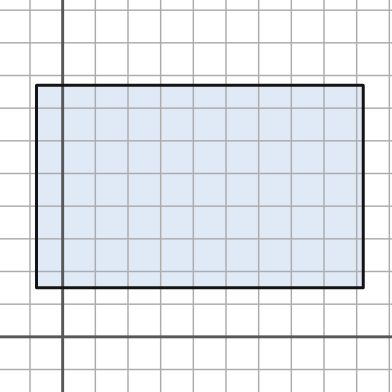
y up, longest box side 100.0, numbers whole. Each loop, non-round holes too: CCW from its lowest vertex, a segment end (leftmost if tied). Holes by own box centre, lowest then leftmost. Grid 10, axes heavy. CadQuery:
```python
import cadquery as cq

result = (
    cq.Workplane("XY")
    .moveTo(-8.0, 15.0)
    .lineTo(92.0, 15.0)
    .lineTo(92.0, 77.0)
    .lineTo(-8.0, 77.0)
    .close()
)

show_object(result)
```